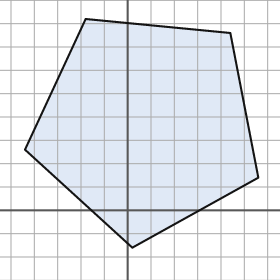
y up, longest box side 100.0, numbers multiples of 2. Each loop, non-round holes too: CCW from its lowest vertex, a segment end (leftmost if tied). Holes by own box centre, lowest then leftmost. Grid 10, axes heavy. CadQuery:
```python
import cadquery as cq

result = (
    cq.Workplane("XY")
    .moveTo(2.0, -16.0)
    .lineTo(56.0, 14.0)
    .lineTo(44.0, 76.0)
    .lineTo(-18.0, 82.0)
    .lineTo(-44.0, 26.0)
    .close()
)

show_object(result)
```